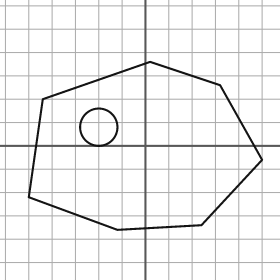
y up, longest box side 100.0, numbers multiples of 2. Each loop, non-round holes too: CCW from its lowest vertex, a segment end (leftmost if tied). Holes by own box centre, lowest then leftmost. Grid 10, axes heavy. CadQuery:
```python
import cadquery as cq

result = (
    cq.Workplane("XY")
    .moveTo(-12.0, -36.0)
    .lineTo(24.0, -34.0)
    .lineTo(50.0, -6.0)
    .lineTo(32.0, 26.0)
    .lineTo(2.0, 36.0)
    .lineTo(-44.0, 20.0)
    .lineTo(-50.0, -22.0)
    .close()
    .moveTo(-20.0, 8.0)
    .circle(8.0)
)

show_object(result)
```